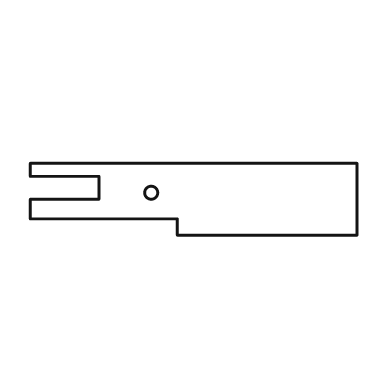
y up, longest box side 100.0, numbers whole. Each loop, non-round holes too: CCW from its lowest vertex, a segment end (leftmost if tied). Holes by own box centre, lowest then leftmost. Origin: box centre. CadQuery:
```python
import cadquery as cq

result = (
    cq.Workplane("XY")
    .moveTo(-5.0, -11.0)
    .lineTo(50.0, -11.0)
    .lineTo(50.0, 11.0)
    .lineTo(-50.0, 11.0)
    .lineTo(-50.0, 7.0)
    .lineTo(-29.0, 7.0)
    .lineTo(-29.0, 0.0)
    .lineTo(-50.0, 0.0)
    .lineTo(-50.0, -6.0)
    .lineTo(-5.0, -6.0)
    .close()
    .moveTo(-13.0, 2.0)
    .circle(2.0)
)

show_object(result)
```